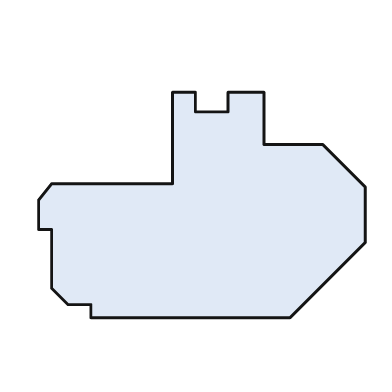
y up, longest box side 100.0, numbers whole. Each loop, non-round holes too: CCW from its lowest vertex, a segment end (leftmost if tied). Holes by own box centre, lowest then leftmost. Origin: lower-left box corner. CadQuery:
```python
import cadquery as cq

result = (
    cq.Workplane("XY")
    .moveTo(16.0, 0.0)
    .lineTo(77.0, 0.0)
    .lineTo(100.0, 23.0)
    .lineTo(100.0, 40.0)
    .lineTo(87.0, 53.0)
    .lineTo(69.0, 53.0)
    .lineTo(69.0, 69.0)
    .lineTo(58.0, 69.0)
    .lineTo(58.0, 63.0)
    .lineTo(48.0, 63.0)
    .lineTo(48.0, 69.0)
    .lineTo(41.0, 69.0)
    .lineTo(41.0, 41.0)
    .lineTo(4.0, 41.0)
    .lineTo(0.0, 36.0)
    .lineTo(0.0, 27.0)
    .lineTo(4.0, 27.0)
    .lineTo(4.0, 9.0)
    .lineTo(9.0, 4.0)
    .lineTo(16.0, 4.0)
    .close()
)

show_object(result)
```